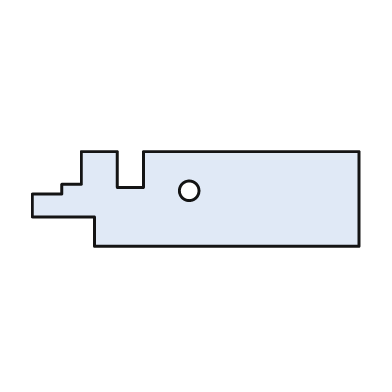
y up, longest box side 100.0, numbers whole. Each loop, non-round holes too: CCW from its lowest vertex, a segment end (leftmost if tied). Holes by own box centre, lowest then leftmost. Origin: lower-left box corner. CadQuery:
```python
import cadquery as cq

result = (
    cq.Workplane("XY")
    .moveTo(19.0, 0.0)
    .lineTo(100.0, 0.0)
    .lineTo(100.0, 29.0)
    .lineTo(34.0, 29.0)
    .lineTo(34.0, 18.0)
    .lineTo(26.0, 18.0)
    .lineTo(26.0, 29.0)
    .lineTo(15.0, 29.0)
    .lineTo(15.0, 19.0)
    .lineTo(9.0, 19.0)
    .lineTo(9.0, 16.0)
    .lineTo(0.0, 16.0)
    .lineTo(0.0, 9.0)
    .lineTo(19.0, 9.0)
    .close()
    .moveTo(48.0, 17.0)
    .circle(3.0)
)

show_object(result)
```